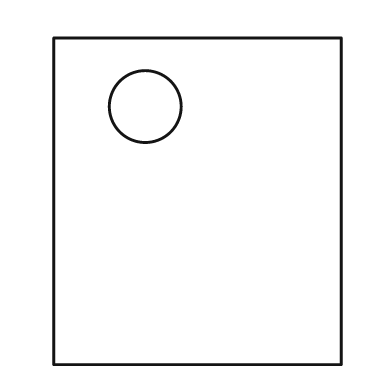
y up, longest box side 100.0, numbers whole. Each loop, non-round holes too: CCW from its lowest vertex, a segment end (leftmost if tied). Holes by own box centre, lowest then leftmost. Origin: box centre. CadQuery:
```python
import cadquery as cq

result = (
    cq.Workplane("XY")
    .moveTo(-44.0, -50.0)
    .lineTo(44.0, -50.0)
    .lineTo(44.0, 50.0)
    .lineTo(-44.0, 50.0)
    .close()
    .moveTo(-16.0, 29.0)
    .circle(11.0)
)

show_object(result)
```